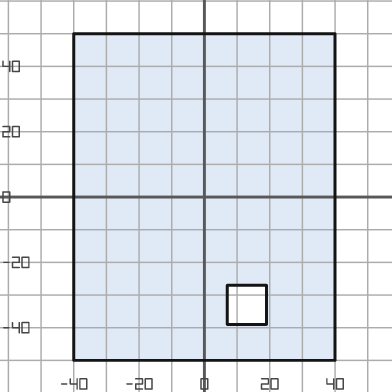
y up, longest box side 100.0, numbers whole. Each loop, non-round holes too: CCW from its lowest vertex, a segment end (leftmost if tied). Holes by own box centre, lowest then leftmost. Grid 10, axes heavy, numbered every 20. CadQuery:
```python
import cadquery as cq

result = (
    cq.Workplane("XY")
    .moveTo(-40.0, -50.0)
    .lineTo(40.0, -50.0)
    .lineTo(40.0, 50.0)
    .lineTo(-40.0, 50.0)
    .close()
    .moveTo(7.0, -39.0)
    .lineTo(19.0, -39.0)
    .lineTo(19.0, -27.0)
    .lineTo(7.0, -27.0)
    .close()
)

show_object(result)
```